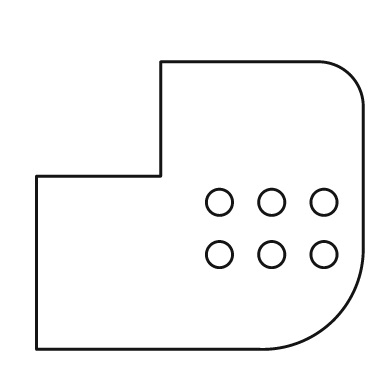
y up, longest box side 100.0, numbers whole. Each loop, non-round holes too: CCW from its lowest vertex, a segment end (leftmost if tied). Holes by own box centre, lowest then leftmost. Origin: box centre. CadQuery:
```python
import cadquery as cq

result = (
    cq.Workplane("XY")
    .moveTo(-50.0, -44.0)
    .lineTo(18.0, -44.0)
    .threePointArc((41.0, -35.0), (50.0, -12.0))
    .lineTo(50.0, 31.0)
    .threePointArc((46.0, 40.0), (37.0, 44.0))
    .lineTo(-12.0, 44.0)
    .lineTo(-12.0, 9.0)
    .lineTo(-50.0, 9.0)
    .close()
    .moveTo(6.0, -15.0)
    .circle(4.0)
    .moveTo(22.0, -15.0)
    .circle(4.0)
    .moveTo(38.0, -15.0)
    .circle(4.0)
    .moveTo(6.0, 1.0)
    .circle(4.0)
    .moveTo(22.0, 1.0)
    .circle(4.0)
    .moveTo(38.0, 1.0)
    .circle(4.0)
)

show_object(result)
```